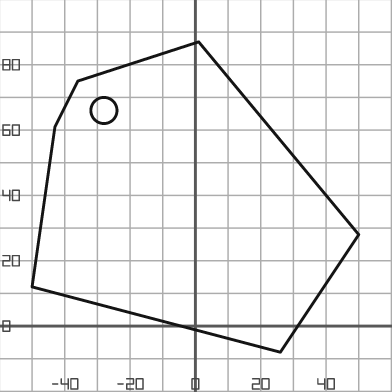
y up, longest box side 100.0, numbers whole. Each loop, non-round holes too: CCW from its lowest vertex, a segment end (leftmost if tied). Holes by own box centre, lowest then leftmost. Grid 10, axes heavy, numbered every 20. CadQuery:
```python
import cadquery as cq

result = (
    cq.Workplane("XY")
    .moveTo(26.0, -8.0)
    .lineTo(50.0, 28.0)
    .lineTo(1.0, 87.0)
    .lineTo(-36.0, 75.0)
    .lineTo(-43.0, 61.0)
    .lineTo(-50.0, 12.0)
    .close()
    .moveTo(-28.0, 66.0)
    .circle(4.0)
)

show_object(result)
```